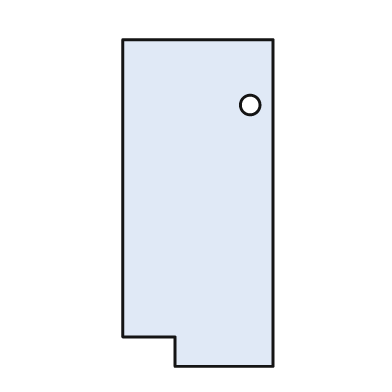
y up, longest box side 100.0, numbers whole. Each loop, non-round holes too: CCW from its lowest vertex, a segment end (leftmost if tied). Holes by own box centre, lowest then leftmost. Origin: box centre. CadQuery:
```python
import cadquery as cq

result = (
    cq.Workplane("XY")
    .moveTo(-7.0, -50.0)
    .lineTo(23.0, -50.0)
    .lineTo(23.0, 50.0)
    .lineTo(-23.0, 50.0)
    .lineTo(-23.0, -41.0)
    .lineTo(-7.0, -41.0)
    .close()
    .moveTo(16.0, 30.0)
    .circle(3.0)
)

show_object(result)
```